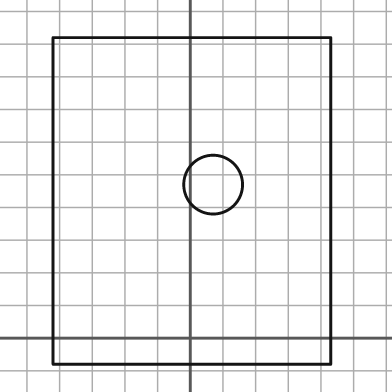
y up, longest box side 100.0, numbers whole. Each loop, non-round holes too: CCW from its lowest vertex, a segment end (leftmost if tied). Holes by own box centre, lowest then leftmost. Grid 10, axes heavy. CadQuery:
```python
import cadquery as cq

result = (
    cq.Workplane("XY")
    .moveTo(-42.0, -8.0)
    .lineTo(43.0, -8.0)
    .lineTo(43.0, 92.0)
    .lineTo(-42.0, 92.0)
    .close()
    .moveTo(7.0, 47.0)
    .circle(9.0)
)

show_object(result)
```